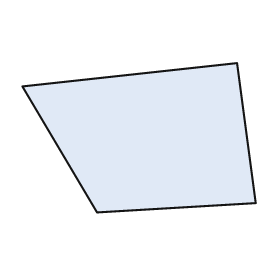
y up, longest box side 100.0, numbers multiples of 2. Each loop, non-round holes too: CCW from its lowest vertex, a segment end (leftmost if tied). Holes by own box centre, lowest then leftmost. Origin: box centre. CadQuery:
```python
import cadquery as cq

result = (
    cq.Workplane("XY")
    .moveTo(-18.0, -32.0)
    .lineTo(50.0, -28.0)
    .lineTo(42.0, 32.0)
    .lineTo(-50.0, 22.0)
    .close()
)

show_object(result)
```